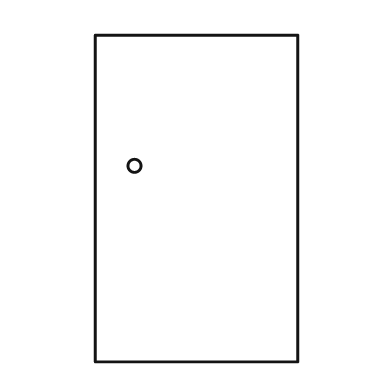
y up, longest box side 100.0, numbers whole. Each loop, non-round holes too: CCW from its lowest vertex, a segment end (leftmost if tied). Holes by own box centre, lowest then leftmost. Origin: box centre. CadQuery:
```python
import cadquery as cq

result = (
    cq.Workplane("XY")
    .moveTo(-31.0, -50.0)
    .lineTo(31.0, -50.0)
    .lineTo(31.0, 50.0)
    .lineTo(-31.0, 50.0)
    .close()
    .moveTo(-19.0, 10.0)
    .circle(2.0)
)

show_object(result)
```